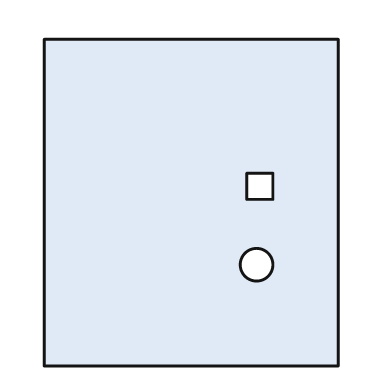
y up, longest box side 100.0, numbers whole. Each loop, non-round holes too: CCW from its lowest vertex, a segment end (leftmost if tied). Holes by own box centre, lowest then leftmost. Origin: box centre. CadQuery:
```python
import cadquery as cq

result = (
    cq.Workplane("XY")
    .moveTo(-45.0, -50.0)
    .lineTo(45.0, -50.0)
    .lineTo(45.0, 50.0)
    .lineTo(-45.0, 50.0)
    .close()
    .moveTo(20.0, -19.0)
    .circle(5.0)
    .moveTo(17.0, 1.0)
    .lineTo(25.0, 1.0)
    .lineTo(25.0, 9.0)
    .lineTo(17.0, 9.0)
    .close()
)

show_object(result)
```